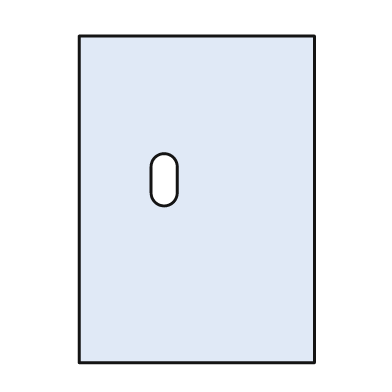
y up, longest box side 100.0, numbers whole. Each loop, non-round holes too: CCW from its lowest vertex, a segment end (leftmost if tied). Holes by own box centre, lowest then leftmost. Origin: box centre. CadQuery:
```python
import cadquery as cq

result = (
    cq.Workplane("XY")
    .moveTo(-36.0, -50.0)
    .lineTo(36.0, -50.0)
    .lineTo(36.0, 50.0)
    .lineTo(-36.0, 50.0)
    .close()
    .moveTo(-14.0, 2.0)
    .threePointArc((-10.0, -2.0), (-6.0, 2.0))
    .lineTo(-6.0, 10.0)
    .threePointArc((-10.0, 14.0), (-14.0, 10.0))
    .close()
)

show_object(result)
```